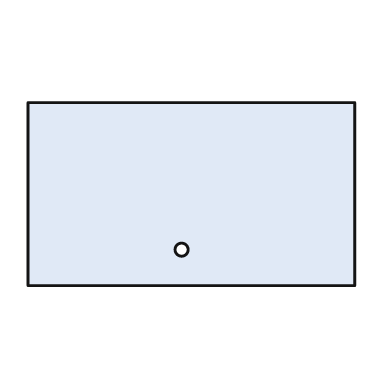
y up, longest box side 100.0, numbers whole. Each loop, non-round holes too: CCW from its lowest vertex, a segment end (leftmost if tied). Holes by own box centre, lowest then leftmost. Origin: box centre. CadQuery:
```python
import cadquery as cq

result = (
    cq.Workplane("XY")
    .moveTo(-50.0, -28.0)
    .lineTo(50.0, -28.0)
    .lineTo(50.0, 28.0)
    .lineTo(-50.0, 28.0)
    .close()
    .moveTo(-3.0, -17.0)
    .circle(2.0)
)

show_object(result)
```